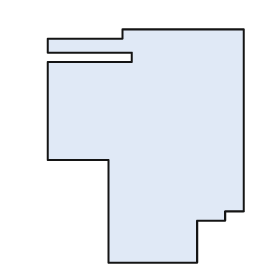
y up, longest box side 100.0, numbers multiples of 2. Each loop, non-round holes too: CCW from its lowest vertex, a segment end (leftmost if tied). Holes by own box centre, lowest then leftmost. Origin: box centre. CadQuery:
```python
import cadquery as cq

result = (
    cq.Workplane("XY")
    .moveTo(-16.0, -50.0)
    .lineTo(22.0, -50.0)
    .lineTo(22.0, -32.0)
    .lineTo(34.0, -32.0)
    .lineTo(34.0, -28.0)
    .lineTo(42.0, -28.0)
    .lineTo(42.0, 50.0)
    .lineTo(-10.0, 50.0)
    .lineTo(-10.0, 46.0)
    .lineTo(-42.0, 46.0)
    .lineTo(-42.0, 40.0)
    .lineTo(-6.0, 40.0)
    .lineTo(-6.0, 36.0)
    .lineTo(-42.0, 36.0)
    .lineTo(-42.0, -6.0)
    .lineTo(-16.0, -6.0)
    .close()
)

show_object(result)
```